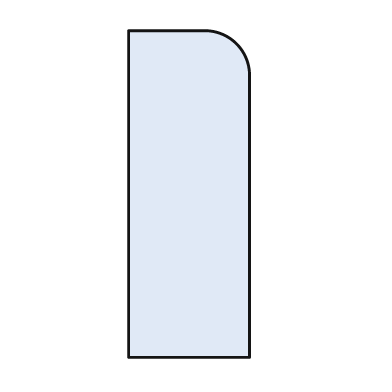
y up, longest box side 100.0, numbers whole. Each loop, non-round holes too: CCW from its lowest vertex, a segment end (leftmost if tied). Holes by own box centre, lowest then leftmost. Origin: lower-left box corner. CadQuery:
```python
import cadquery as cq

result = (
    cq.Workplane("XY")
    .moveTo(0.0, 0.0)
    .lineTo(37.0, 0.0)
    .lineTo(37.0, 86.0)
    .threePointArc((33.0, 96.0), (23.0, 100.0))
    .lineTo(0.0, 100.0)
    .close()
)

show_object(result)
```